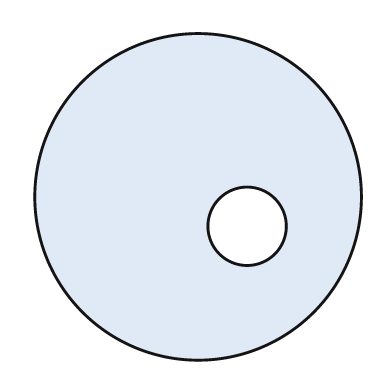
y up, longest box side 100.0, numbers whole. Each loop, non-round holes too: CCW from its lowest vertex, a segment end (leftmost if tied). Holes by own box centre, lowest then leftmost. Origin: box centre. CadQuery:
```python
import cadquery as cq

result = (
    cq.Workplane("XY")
    .moveTo(0.0, 0.0)
    .circle(50.0)
    .moveTo(15.0, -9.0)
    .circle(12.0)
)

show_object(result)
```